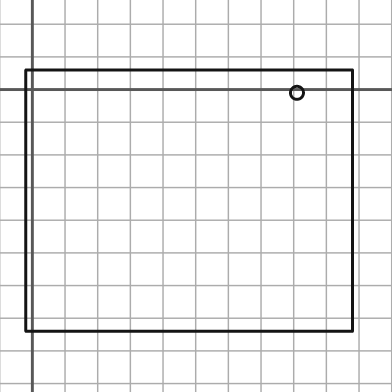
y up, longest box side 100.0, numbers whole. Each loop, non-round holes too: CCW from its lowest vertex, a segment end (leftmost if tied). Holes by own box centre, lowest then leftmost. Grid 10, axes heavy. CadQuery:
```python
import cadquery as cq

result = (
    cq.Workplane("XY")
    .moveTo(-2.0, -74.0)
    .lineTo(98.0, -74.0)
    .lineTo(98.0, 6.0)
    .lineTo(-2.0, 6.0)
    .close()
    .moveTo(81.0, -1.0)
    .circle(2.0)
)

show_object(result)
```